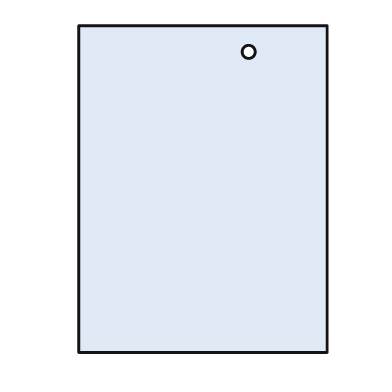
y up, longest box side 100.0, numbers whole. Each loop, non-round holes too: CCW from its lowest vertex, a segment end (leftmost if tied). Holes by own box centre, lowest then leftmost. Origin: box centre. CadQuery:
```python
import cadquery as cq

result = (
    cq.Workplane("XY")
    .moveTo(-38.0, -50.0)
    .lineTo(38.0, -50.0)
    .lineTo(38.0, 50.0)
    .lineTo(-38.0, 50.0)
    .close()
    .moveTo(14.0, 42.0)
    .circle(2.0)
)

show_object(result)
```